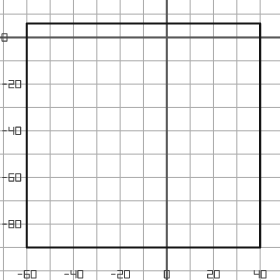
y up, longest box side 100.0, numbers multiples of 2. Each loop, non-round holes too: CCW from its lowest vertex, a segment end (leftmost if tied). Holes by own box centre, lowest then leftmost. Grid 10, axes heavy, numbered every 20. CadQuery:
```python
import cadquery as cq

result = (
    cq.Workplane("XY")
    .moveTo(-60.0, -90.0)
    .lineTo(40.0, -90.0)
    .lineTo(40.0, 6.0)
    .lineTo(-60.0, 6.0)
    .close()
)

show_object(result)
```